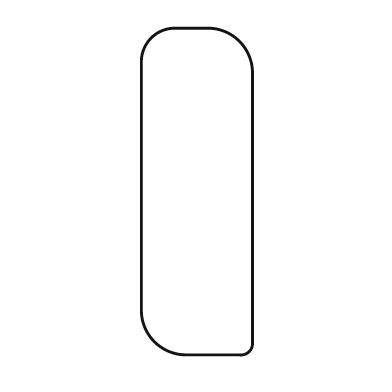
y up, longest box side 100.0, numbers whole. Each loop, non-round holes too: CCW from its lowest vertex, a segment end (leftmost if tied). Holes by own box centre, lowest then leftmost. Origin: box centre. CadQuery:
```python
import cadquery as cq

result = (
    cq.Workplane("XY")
    .moveTo(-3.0, -50.0)
    .lineTo(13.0, -50.0)
    .threePointArc((16.0, -49.0), (17.0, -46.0))
    .lineTo(17.0, 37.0)
    .threePointArc((13.0, 46.0), (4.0, 50.0))
    .lineTo(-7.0, 50.0)
    .threePointArc((-14.0, 47.0), (-17.0, 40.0))
    .lineTo(-17.0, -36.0)
    .threePointArc((-13.0, -46.0), (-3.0, -50.0))
    .close()
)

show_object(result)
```